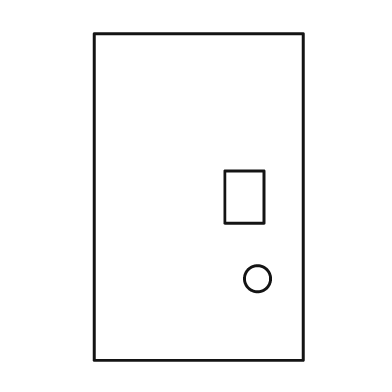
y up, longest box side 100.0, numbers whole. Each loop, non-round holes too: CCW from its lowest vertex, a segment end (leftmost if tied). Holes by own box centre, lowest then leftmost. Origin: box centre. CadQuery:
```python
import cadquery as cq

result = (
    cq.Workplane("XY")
    .moveTo(-32.0, -50.0)
    .lineTo(32.0, -50.0)
    .lineTo(32.0, 50.0)
    .lineTo(-32.0, 50.0)
    .close()
    .moveTo(18.0, -25.0)
    .circle(4.0)
    .moveTo(8.0, -8.0)
    .lineTo(20.0, -8.0)
    .lineTo(20.0, 8.0)
    .lineTo(8.0, 8.0)
    .close()
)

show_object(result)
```